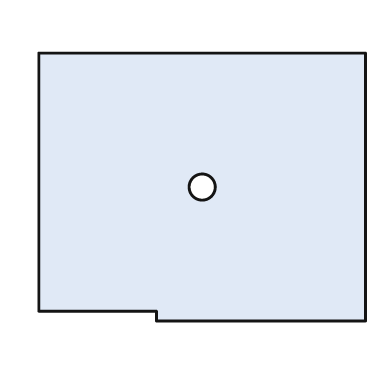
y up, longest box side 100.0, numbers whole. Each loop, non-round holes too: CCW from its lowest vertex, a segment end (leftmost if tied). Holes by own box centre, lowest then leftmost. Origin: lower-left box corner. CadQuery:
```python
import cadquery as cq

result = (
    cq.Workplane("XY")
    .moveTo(36.0, 0.0)
    .lineTo(100.0, 0.0)
    .lineTo(100.0, 82.0)
    .lineTo(0.0, 82.0)
    .lineTo(0.0, 3.0)
    .lineTo(36.0, 3.0)
    .close()
    .moveTo(50.0, 41.0)
    .circle(4.0)
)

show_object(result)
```